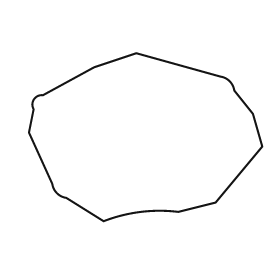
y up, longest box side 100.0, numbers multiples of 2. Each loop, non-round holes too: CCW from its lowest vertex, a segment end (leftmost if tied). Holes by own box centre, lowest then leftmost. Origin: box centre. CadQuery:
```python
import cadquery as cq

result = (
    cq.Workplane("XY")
    .moveTo(-18.0, -36.0)
    .threePointArc((-2.0, -32.0), (14.0, -32.0))
    .lineTo(30.0, -28.0)
    .lineTo(50.0, -4.0)
    .lineTo(46.0, 10.0)
    .lineTo(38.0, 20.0)
    .threePointArc((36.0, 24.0), (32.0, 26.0))
    .lineTo(-4.0, 36.0)
    .lineTo(-22.0, 30.0)
    .lineTo(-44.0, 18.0)
    .threePointArc((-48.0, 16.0), (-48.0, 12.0))
    .lineTo(-50.0, 2.0)
    .lineTo(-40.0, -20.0)
    .threePointArc((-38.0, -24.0), (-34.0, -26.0))
    .close()
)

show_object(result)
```